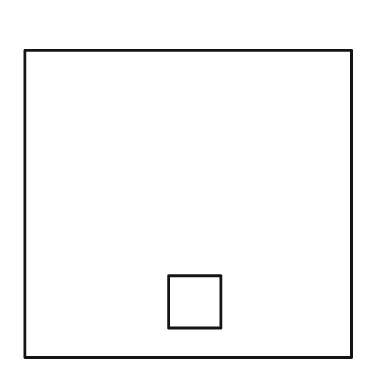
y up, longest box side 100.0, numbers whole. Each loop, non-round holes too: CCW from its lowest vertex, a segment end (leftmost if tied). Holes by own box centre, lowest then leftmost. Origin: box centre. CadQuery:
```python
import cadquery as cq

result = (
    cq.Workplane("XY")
    .moveTo(-50.0, -47.0)
    .lineTo(50.0, -47.0)
    .lineTo(50.0, 47.0)
    .lineTo(-50.0, 47.0)
    .close()
    .moveTo(-6.0, -38.0)
    .lineTo(10.0, -38.0)
    .lineTo(10.0, -22.0)
    .lineTo(-6.0, -22.0)
    .close()
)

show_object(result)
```